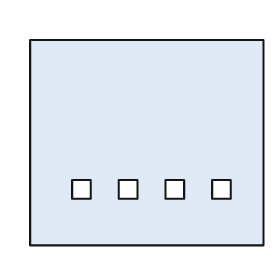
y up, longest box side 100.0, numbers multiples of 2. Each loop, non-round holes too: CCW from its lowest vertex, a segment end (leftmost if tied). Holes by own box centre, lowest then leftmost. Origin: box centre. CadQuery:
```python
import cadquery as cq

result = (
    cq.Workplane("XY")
    .moveTo(-50.0, -44.0)
    .lineTo(50.0, -44.0)
    .lineTo(50.0, 44.0)
    .lineTo(-50.0, 44.0)
    .close()
    .moveTo(-32.0, -24.0)
    .lineTo(-24.0, -24.0)
    .lineTo(-24.0, -16.0)
    .lineTo(-32.0, -16.0)
    .close()
    .moveTo(-12.0, -24.0)
    .lineTo(-4.0, -24.0)
    .lineTo(-4.0, -16.0)
    .lineTo(-12.0, -16.0)
    .close()
    .moveTo(8.0, -24.0)
    .lineTo(16.0, -24.0)
    .lineTo(16.0, -16.0)
    .lineTo(8.0, -16.0)
    .close()
    .moveTo(28.0, -24.0)
    .lineTo(36.0, -24.0)
    .lineTo(36.0, -16.0)
    .lineTo(28.0, -16.0)
    .close()
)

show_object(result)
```